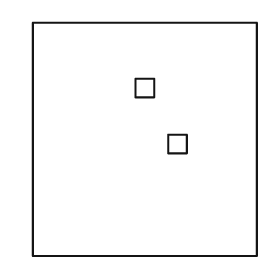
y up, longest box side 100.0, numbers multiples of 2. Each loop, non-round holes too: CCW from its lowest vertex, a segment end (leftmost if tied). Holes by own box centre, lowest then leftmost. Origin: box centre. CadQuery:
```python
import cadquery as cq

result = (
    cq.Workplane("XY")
    .moveTo(-48.0, -50.0)
    .lineTo(48.0, -50.0)
    .lineTo(48.0, 50.0)
    .lineTo(-48.0, 50.0)
    .close()
    .moveTo(10.0, -6.0)
    .lineTo(18.0, -6.0)
    .lineTo(18.0, 2.0)
    .lineTo(10.0, 2.0)
    .close()
    .moveTo(-4.0, 18.0)
    .lineTo(4.0, 18.0)
    .lineTo(4.0, 26.0)
    .lineTo(-4.0, 26.0)
    .close()
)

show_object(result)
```